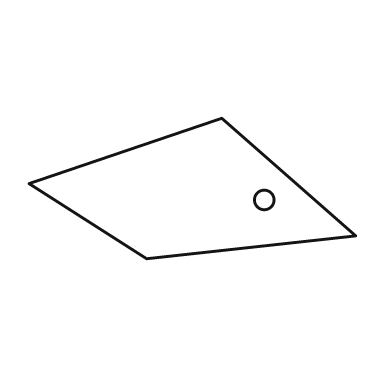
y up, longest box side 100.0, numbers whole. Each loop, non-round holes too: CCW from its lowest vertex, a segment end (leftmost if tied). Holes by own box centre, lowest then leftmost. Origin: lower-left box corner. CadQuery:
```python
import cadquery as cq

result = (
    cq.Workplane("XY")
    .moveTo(36.0, 0.0)
    .lineTo(100.0, 7.0)
    .lineTo(59.0, 43.0)
    .lineTo(0.0, 23.0)
    .close()
    .moveTo(72.0, 18.0)
    .circle(3.0)
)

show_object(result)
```